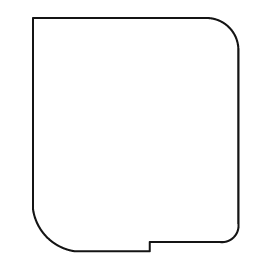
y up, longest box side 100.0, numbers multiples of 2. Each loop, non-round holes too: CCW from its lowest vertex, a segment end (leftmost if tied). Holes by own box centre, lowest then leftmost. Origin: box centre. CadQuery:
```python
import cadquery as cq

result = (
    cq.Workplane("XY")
    .moveTo(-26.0, -50.0)
    .lineTo(6.0, -50.0)
    .lineTo(6.0, -46.0)
    .lineTo(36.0, -46.0)
    .threePointArc((42.0, -44.0), (44.0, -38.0))
    .lineTo(44.0, 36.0)
    .threePointArc((40.0, 46.0), (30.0, 50.0))
    .lineTo(-44.0, 50.0)
    .lineTo(-44.0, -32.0)
    .threePointArc((-38.0, -44.0), (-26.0, -50.0))
    .close()
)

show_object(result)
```